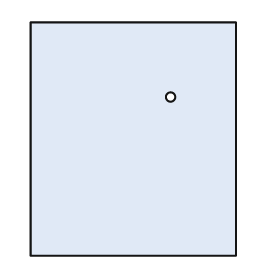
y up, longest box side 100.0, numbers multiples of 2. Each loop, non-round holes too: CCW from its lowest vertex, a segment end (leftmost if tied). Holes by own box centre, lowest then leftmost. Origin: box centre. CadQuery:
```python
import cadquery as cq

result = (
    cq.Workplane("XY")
    .moveTo(-44.0, -50.0)
    .lineTo(44.0, -50.0)
    .lineTo(44.0, 50.0)
    .lineTo(-44.0, 50.0)
    .close()
    .moveTo(16.0, 18.0)
    .circle(2.0)
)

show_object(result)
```